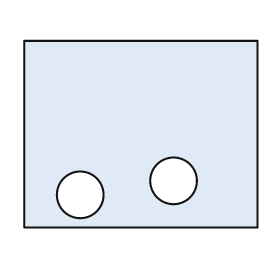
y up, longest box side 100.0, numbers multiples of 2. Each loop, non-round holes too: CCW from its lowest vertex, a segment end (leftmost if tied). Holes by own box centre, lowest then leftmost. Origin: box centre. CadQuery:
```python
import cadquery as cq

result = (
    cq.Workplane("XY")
    .moveTo(-50.0, -40.0)
    .lineTo(50.0, -40.0)
    .lineTo(50.0, 40.0)
    .lineTo(-50.0, 40.0)
    .close()
    .moveTo(-26.0, -26.0)
    .circle(10.0)
    .moveTo(14.0, -20.0)
    .circle(10.0)
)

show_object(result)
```